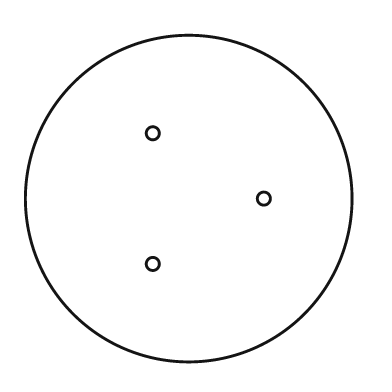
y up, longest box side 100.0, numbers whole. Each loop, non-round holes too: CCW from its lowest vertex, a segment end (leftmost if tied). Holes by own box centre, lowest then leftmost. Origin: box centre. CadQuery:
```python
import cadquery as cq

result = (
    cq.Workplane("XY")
    .moveTo(0.0, 0.0)
    .circle(50.0)
    .moveTo(-11.0, -20.0)
    .circle(2.0)
    .moveTo(23.0, 0.0)
    .circle(2.0)
    .moveTo(-11.0, 20.0)
    .circle(2.0)
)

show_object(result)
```